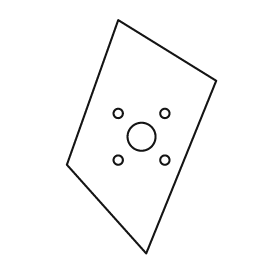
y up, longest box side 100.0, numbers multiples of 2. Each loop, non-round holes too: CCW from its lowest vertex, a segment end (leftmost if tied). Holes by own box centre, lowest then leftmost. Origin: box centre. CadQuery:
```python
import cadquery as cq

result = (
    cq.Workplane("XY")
    .moveTo(2.0, -50.0)
    .lineTo(32.0, 24.0)
    .lineTo(-10.0, 50.0)
    .lineTo(-32.0, -12.0)
    .close()
    .moveTo(-10.0, -10.0)
    .circle(2.0)
    .moveTo(10.0, -10.0)
    .circle(2.0)
    .moveTo(0.0, 0.0)
    .circle(6.0)
    .moveTo(-10.0, 10.0)
    .circle(2.0)
    .moveTo(10.0, 10.0)
    .circle(2.0)
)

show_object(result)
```